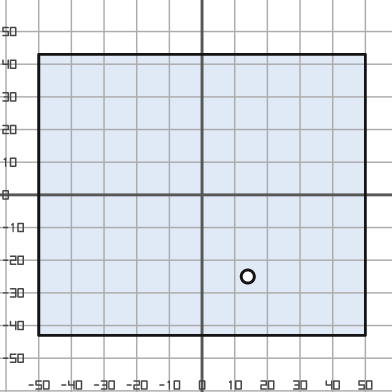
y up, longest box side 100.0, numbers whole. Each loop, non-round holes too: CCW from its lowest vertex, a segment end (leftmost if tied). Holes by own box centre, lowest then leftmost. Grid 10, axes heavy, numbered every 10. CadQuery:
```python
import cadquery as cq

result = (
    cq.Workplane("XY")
    .moveTo(-50.0, -43.0)
    .lineTo(50.0, -43.0)
    .lineTo(50.0, 43.0)
    .lineTo(-50.0, 43.0)
    .close()
    .moveTo(14.0, -25.0)
    .circle(2.0)
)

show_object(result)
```